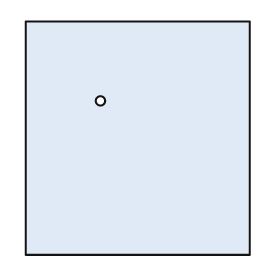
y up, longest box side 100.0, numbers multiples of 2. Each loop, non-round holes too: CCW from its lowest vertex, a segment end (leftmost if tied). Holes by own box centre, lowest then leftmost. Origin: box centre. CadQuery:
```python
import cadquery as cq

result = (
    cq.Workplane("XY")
    .moveTo(-48.0, -50.0)
    .lineTo(48.0, -50.0)
    .lineTo(48.0, 50.0)
    .lineTo(-48.0, 50.0)
    .close()
    .moveTo(-16.0, 16.0)
    .circle(2.0)
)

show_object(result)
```